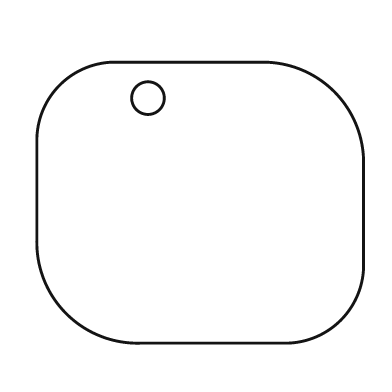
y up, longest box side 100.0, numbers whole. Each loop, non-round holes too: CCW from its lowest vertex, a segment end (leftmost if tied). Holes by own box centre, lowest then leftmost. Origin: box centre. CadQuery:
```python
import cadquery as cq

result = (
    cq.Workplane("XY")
    .moveTo(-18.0, -43.0)
    .lineTo(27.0, -43.0)
    .threePointArc((43.0, -36.0), (50.0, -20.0))
    .lineTo(50.0, 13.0)
    .threePointArc((41.0, 34.0), (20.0, 43.0))
    .lineTo(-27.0, 43.0)
    .threePointArc((-43.0, 36.0), (-50.0, 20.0))
    .lineTo(-50.0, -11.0)
    .threePointArc((-41.0, -34.0), (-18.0, -43.0))
    .close()
    .moveTo(-16.0, 32.0)
    .circle(5.0)
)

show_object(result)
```